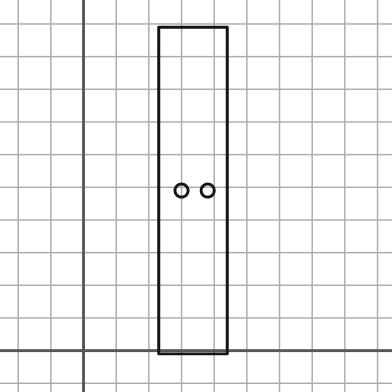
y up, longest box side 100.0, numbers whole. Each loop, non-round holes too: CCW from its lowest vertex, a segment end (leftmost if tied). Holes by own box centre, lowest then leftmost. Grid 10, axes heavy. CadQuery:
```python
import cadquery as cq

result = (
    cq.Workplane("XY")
    .moveTo(23.0, -1.0)
    .lineTo(44.0, -1.0)
    .lineTo(44.0, 99.0)
    .lineTo(23.0, 99.0)
    .close()
    .moveTo(30.0, 49.0)
    .circle(2.0)
    .moveTo(38.0, 49.0)
    .circle(2.0)
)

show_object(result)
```